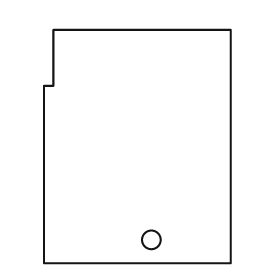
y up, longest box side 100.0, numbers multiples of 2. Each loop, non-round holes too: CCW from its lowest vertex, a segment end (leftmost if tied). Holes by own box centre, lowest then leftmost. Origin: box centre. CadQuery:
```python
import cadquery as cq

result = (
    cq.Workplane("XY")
    .moveTo(-40.0, -50.0)
    .lineTo(40.0, -50.0)
    .lineTo(40.0, 50.0)
    .lineTo(-36.0, 50.0)
    .lineTo(-36.0, 26.0)
    .lineTo(-40.0, 26.0)
    .close()
    .moveTo(6.0, -40.0)
    .circle(4.0)
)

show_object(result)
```